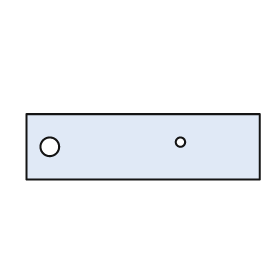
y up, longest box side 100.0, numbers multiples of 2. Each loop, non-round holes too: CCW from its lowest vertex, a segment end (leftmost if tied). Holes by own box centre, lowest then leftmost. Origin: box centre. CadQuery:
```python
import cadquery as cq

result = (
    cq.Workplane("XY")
    .moveTo(-50.0, -14.0)
    .lineTo(50.0, -14.0)
    .lineTo(50.0, 14.0)
    .lineTo(-50.0, 14.0)
    .close()
    .moveTo(-40.0, 0.0)
    .circle(4.0)
    .moveTo(16.0, 2.0)
    .circle(2.0)
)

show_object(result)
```